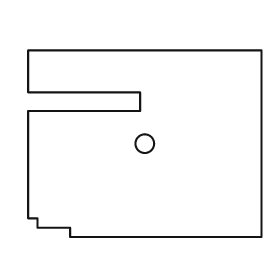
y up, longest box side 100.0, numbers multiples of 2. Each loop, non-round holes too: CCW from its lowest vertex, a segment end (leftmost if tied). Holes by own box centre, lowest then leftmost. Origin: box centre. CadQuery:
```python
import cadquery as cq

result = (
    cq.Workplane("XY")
    .moveTo(-32.0, -40.0)
    .lineTo(50.0, -40.0)
    .lineTo(50.0, 40.0)
    .lineTo(-50.0, 40.0)
    .lineTo(-50.0, 22.0)
    .lineTo(-2.0, 22.0)
    .lineTo(-2.0, 14.0)
    .lineTo(-50.0, 14.0)
    .lineTo(-50.0, -32.0)
    .lineTo(-46.0, -32.0)
    .lineTo(-46.0, -36.0)
    .lineTo(-32.0, -36.0)
    .close()
    .moveTo(0.0, 0.0)
    .circle(4.0)
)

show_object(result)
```